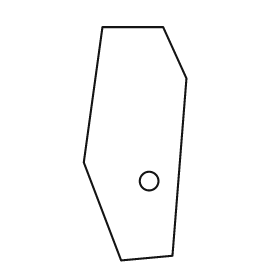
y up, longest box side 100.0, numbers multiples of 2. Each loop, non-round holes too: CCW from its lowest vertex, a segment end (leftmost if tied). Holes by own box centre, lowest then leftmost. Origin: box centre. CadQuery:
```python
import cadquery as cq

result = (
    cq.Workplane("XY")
    .moveTo(-6.0, -50.0)
    .lineTo(16.0, -48.0)
    .lineTo(22.0, 28.0)
    .lineTo(12.0, 50.0)
    .lineTo(-14.0, 50.0)
    .lineTo(-22.0, -8.0)
    .close()
    .moveTo(6.0, -16.0)
    .circle(4.0)
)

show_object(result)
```